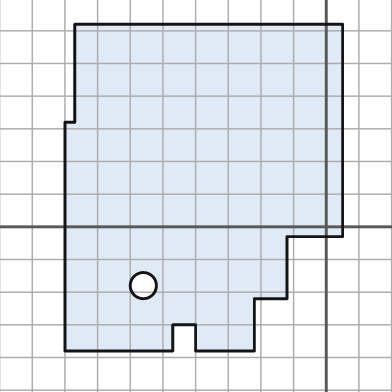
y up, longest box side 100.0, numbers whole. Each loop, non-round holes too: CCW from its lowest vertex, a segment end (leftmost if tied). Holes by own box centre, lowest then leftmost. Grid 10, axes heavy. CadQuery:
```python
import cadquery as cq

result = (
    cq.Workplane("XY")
    .moveTo(-80.0, -38.0)
    .lineTo(-47.0, -38.0)
    .lineTo(-47.0, -30.0)
    .lineTo(-40.0, -30.0)
    .lineTo(-40.0, -38.0)
    .lineTo(-22.0, -38.0)
    .lineTo(-22.0, -22.0)
    .lineTo(-12.0, -22.0)
    .lineTo(-12.0, -3.0)
    .lineTo(5.0, -3.0)
    .lineTo(5.0, 62.0)
    .lineTo(-77.0, 62.0)
    .lineTo(-77.0, 32.0)
    .lineTo(-80.0, 32.0)
    .close()
    .moveTo(-56.0, -18.0)
    .circle(4.0)
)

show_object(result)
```